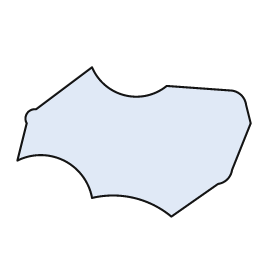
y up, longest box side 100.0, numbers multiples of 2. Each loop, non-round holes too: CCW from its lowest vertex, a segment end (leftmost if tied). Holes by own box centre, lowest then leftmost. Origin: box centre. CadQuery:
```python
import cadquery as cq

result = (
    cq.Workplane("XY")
    .moveTo(16.0, -32.0)
    .lineTo(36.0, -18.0)
    .threePointArc((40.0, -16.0), (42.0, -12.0))
    .lineTo(50.0, 8.0)
    .lineTo(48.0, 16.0)
    .threePointArc((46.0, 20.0), (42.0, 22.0))
    .lineTo(14.0, 24.0)
    .threePointArc((-4.0, 20.0), (-18.0, 32.0))
    .lineTo(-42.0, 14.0)
    .threePointArc((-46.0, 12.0), (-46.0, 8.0))
    .lineTo(-50.0, -8.0)
    .threePointArc((-30.0, -8.0), (-18.0, -24.0))
    .threePointArc((0.0, -24.0), (16.0, -32.0))
    .close()
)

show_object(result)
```